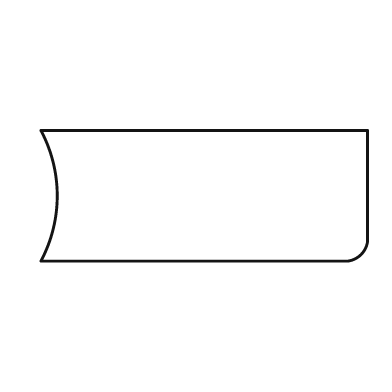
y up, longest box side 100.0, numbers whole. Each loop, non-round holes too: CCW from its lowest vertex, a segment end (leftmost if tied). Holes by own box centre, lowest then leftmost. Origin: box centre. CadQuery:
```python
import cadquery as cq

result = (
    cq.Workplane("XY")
    .moveTo(-50.0, -20.0)
    .lineTo(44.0, -20.0)
    .threePointArc((48.0, -18.0), (50.0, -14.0))
    .lineTo(50.0, 20.0)
    .lineTo(-50.0, 20.0)
    .threePointArc((-45.0, 0.0), (-50.0, -20.0))
    .close()
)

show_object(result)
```